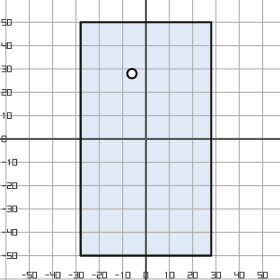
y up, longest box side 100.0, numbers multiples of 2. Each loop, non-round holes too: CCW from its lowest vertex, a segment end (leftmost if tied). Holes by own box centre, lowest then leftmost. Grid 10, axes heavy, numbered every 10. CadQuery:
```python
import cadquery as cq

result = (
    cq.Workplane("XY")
    .moveTo(-28.0, -50.0)
    .lineTo(28.0, -50.0)
    .lineTo(28.0, 50.0)
    .lineTo(-28.0, 50.0)
    .close()
    .moveTo(-6.0, 28.0)
    .circle(2.0)
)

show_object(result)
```